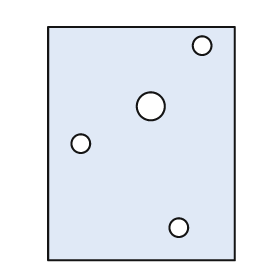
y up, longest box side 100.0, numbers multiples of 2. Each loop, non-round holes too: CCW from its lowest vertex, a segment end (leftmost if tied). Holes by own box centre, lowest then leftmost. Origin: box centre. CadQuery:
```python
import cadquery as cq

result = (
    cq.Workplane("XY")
    .moveTo(-40.0, -50.0)
    .lineTo(40.0, -50.0)
    .lineTo(40.0, 50.0)
    .lineTo(-40.0, 50.0)
    .close()
    .moveTo(16.0, -36.0)
    .circle(4.0)
    .moveTo(-26.0, 0.0)
    .circle(4.0)
    .moveTo(4.0, 16.0)
    .circle(6.0)
    .moveTo(26.0, 42.0)
    .circle(4.0)
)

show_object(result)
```